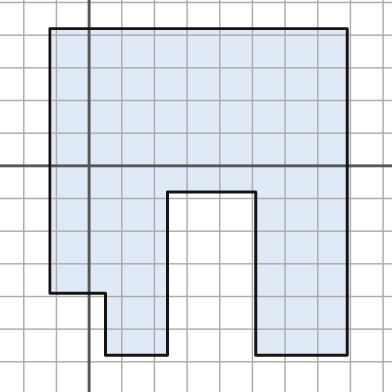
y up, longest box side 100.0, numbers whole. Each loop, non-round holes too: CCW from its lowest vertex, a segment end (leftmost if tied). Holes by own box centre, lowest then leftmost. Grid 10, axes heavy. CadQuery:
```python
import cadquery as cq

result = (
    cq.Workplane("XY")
    .moveTo(5.0, -58.0)
    .lineTo(24.0, -58.0)
    .lineTo(24.0, -8.0)
    .lineTo(51.0, -8.0)
    .lineTo(51.0, -58.0)
    .lineTo(79.0, -58.0)
    .lineTo(79.0, 42.0)
    .lineTo(-12.0, 42.0)
    .lineTo(-12.0, -39.0)
    .lineTo(5.0, -39.0)
    .close()
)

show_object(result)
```